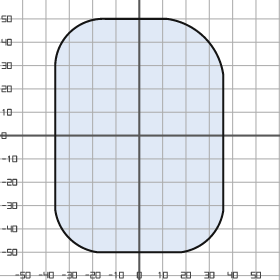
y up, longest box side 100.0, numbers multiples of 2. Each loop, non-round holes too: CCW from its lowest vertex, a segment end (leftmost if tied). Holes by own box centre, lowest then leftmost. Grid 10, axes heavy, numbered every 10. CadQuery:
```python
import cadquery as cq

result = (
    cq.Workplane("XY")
    .moveTo(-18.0, -50.0)
    .lineTo(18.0, -50.0)
    .threePointArc((30.0, -44.0), (36.0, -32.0))
    .lineTo(36.0, 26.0)
    .threePointArc((28.0, 42.0), (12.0, 50.0))
    .lineTo(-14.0, 50.0)
    .threePointArc((-30.0, 44.0), (-36.0, 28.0))
    .lineTo(-36.0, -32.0)
    .threePointArc((-30.0, -44.0), (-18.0, -50.0))
    .close()
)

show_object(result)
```